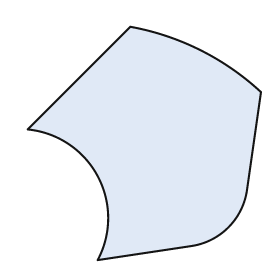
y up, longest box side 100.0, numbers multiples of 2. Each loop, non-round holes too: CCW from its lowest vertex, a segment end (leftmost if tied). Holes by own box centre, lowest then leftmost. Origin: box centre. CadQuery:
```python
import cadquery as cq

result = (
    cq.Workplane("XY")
    .moveTo(-20.0, -50.0)
    .lineTo(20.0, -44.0)
    .threePointArc((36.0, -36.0), (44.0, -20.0))
    .lineTo(50.0, 22.0)
    .threePointArc((24.0, 40.0), (-6.0, 50.0))
    .lineTo(-50.0, 6.0)
    .threePointArc((-20.0, -14.0), (-20.0, -50.0))
    .close()
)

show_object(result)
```